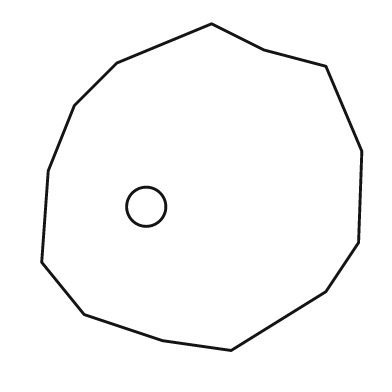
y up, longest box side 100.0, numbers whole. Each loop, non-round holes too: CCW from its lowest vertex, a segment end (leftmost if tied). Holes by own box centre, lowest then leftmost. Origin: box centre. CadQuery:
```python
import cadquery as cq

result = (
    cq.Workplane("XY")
    .moveTo(9.0, -50.0)
    .lineTo(38.0, -32.0)
    .lineTo(48.0, -17.0)
    .lineTo(49.0, 11.0)
    .lineTo(38.0, 37.0)
    .lineTo(19.0, 42.0)
    .lineTo(3.0, 50.0)
    .lineTo(-26.0, 38.0)
    .lineTo(-39.0, 25.0)
    .lineTo(-47.0, 5.0)
    .lineTo(-49.0, -23.0)
    .lineTo(-36.0, -39.0)
    .lineTo(-12.0, -47.0)
    .close()
    .moveTo(-17.0, -6.0)
    .circle(6.0)
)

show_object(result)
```